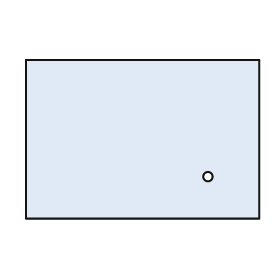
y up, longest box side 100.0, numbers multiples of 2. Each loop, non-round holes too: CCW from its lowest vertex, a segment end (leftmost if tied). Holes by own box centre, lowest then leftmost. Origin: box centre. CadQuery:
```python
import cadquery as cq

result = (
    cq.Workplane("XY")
    .moveTo(-50.0, -34.0)
    .lineTo(50.0, -34.0)
    .lineTo(50.0, 34.0)
    .lineTo(-50.0, 34.0)
    .close()
    .moveTo(28.0, -16.0)
    .circle(2.0)
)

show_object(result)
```